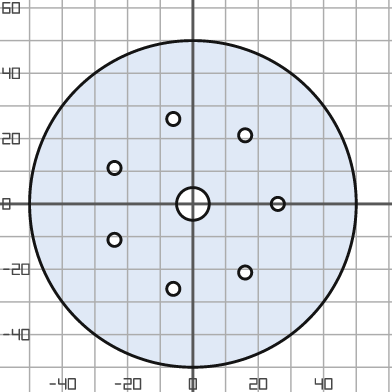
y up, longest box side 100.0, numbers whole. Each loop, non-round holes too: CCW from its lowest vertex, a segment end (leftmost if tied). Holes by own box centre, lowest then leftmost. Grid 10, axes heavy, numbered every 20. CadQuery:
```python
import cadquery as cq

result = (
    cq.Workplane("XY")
    .moveTo(0.0, 0.0)
    .circle(50.0)
    .moveTo(-6.0, -26.0)
    .circle(2.0)
    .moveTo(16.0, -21.0)
    .circle(2.0)
    .moveTo(-24.0, -11.0)
    .circle(2.0)
    .moveTo(0.0, 0.0)
    .circle(5.0)
    .moveTo(26.0, 0.0)
    .circle(2.0)
    .moveTo(-24.0, 11.0)
    .circle(2.0)
    .moveTo(16.0, 21.0)
    .circle(2.0)
    .moveTo(-6.0, 26.0)
    .circle(2.0)
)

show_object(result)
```